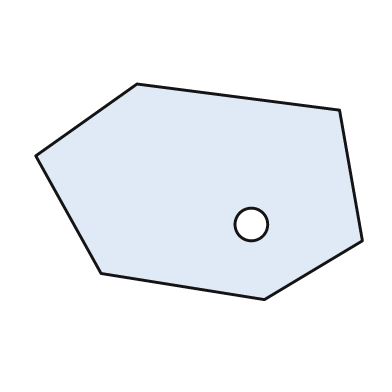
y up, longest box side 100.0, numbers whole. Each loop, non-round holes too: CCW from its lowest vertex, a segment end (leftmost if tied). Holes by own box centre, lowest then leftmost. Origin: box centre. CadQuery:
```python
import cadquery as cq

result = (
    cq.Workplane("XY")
    .moveTo(20.0, -33.0)
    .lineTo(50.0, -15.0)
    .lineTo(43.0, 25.0)
    .lineTo(-19.0, 33.0)
    .lineTo(-50.0, 11.0)
    .lineTo(-30.0, -25.0)
    .close()
    .moveTo(16.0, -10.0)
    .circle(5.0)
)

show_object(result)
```